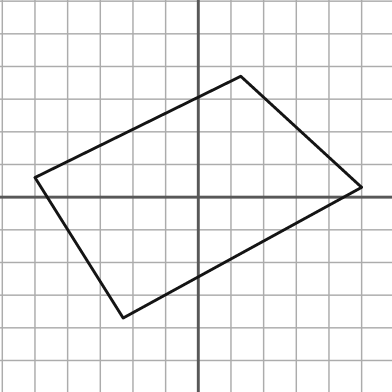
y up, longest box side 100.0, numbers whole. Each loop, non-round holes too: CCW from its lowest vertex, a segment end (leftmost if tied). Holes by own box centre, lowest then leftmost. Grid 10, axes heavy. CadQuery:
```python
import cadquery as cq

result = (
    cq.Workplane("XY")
    .moveTo(-23.0, -37.0)
    .lineTo(50.0, 3.0)
    .lineTo(13.0, 37.0)
    .lineTo(-50.0, 6.0)
    .close()
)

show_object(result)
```